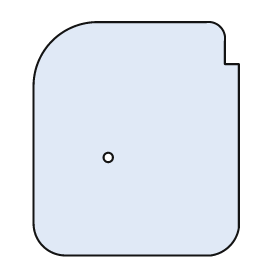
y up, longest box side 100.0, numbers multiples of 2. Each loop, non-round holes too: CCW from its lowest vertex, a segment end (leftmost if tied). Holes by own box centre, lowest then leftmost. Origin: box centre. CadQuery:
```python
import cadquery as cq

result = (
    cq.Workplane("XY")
    .moveTo(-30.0, -50.0)
    .lineTo(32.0, -50.0)
    .threePointArc((40.0, -46.0), (44.0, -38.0))
    .lineTo(44.0, 32.0)
    .lineTo(38.0, 32.0)
    .lineTo(38.0, 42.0)
    .threePointArc((36.0, 48.0), (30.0, 50.0))
    .lineTo(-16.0, 50.0)
    .threePointArc((-36.0, 42.0), (-44.0, 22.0))
    .lineTo(-44.0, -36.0)
    .threePointArc((-40.0, -46.0), (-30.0, -50.0))
    .close()
    .moveTo(-12.0, -8.0)
    .circle(2.0)
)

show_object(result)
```